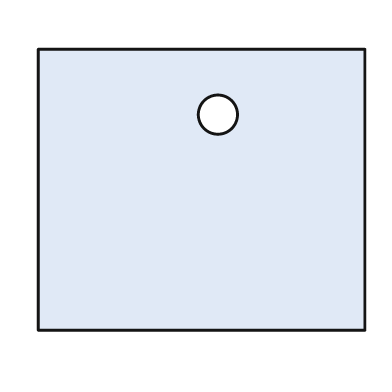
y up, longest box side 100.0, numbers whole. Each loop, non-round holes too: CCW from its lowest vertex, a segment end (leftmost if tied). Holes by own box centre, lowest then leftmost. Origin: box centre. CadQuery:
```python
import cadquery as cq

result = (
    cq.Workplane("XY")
    .moveTo(-50.0, -43.0)
    .lineTo(50.0, -43.0)
    .lineTo(50.0, 43.0)
    .lineTo(-50.0, 43.0)
    .close()
    .moveTo(5.0, 23.0)
    .circle(6.0)
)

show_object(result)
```